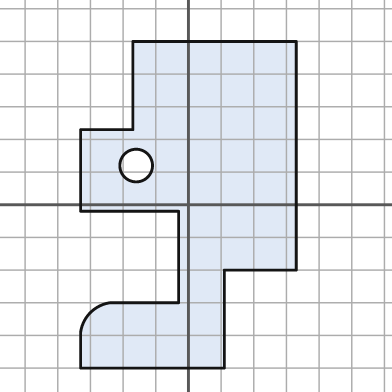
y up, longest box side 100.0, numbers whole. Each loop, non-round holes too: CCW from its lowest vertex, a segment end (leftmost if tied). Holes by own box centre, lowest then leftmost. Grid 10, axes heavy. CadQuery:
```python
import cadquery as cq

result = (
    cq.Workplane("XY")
    .moveTo(-33.0, -50.0)
    .lineTo(11.0, -50.0)
    .lineTo(11.0, -20.0)
    .lineTo(33.0, -20.0)
    .lineTo(33.0, 50.0)
    .lineTo(-17.0, 50.0)
    .lineTo(-17.0, 23.0)
    .lineTo(-33.0, 23.0)
    .lineTo(-33.0, -2.0)
    .lineTo(-3.0, -2.0)
    .lineTo(-3.0, -30.0)
    .lineTo(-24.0, -30.0)
    .threePointArc((-30.0, -33.0), (-33.0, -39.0))
    .close()
    .moveTo(-16.0, 12.0)
    .circle(5.0)
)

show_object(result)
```